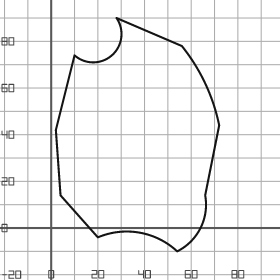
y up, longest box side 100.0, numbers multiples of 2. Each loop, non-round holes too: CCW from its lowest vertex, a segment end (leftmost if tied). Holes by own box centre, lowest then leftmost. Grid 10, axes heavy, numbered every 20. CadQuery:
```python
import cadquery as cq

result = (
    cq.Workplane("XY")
    .moveTo(54.0, -10.0)
    .threePointArc((64.0, 0.0), (66.0, 14.0))
    .lineTo(72.0, 44.0)
    .threePointArc((66.0, 62.0), (56.0, 78.0))
    .lineTo(28.0, 90.0)
    .threePointArc((26.0, 74.0), (10.0, 74.0))
    .lineTo(2.0, 42.0)
    .lineTo(4.0, 14.0)
    .lineTo(20.0, -4.0)
    .threePointArc((38.0, -2.0), (54.0, -10.0))
    .close()
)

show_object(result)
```